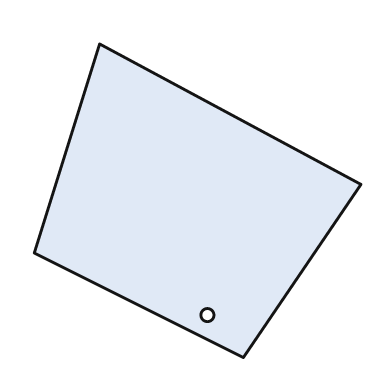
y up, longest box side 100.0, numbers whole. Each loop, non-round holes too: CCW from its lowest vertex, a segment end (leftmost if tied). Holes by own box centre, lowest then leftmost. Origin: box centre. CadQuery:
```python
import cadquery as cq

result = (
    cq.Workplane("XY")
    .moveTo(14.0, -48.0)
    .lineTo(50.0, 5.0)
    .lineTo(-30.0, 48.0)
    .lineTo(-50.0, -16.0)
    .close()
    .moveTo(3.0, -35.0)
    .circle(2.0)
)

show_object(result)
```